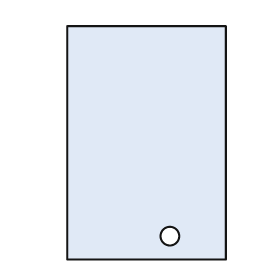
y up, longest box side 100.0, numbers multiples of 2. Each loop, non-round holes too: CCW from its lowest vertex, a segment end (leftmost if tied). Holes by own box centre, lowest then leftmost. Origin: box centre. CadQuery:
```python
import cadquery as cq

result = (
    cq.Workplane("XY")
    .moveTo(-34.0, -50.0)
    .lineTo(34.0, -50.0)
    .lineTo(34.0, 50.0)
    .lineTo(-34.0, 50.0)
    .close()
    .moveTo(10.0, -40.0)
    .circle(4.0)
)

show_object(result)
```